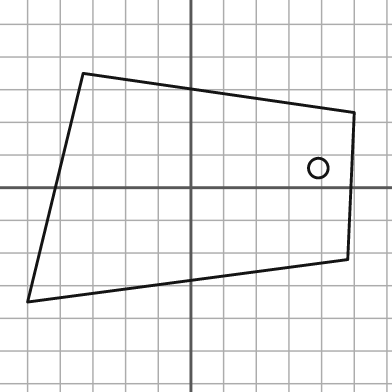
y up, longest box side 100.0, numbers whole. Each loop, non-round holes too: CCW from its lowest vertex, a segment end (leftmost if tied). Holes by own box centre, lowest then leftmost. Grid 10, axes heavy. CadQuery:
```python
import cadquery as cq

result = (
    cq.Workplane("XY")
    .moveTo(-50.0, -35.0)
    .lineTo(48.0, -22.0)
    .lineTo(50.0, 23.0)
    .lineTo(-33.0, 35.0)
    .close()
    .moveTo(39.0, 6.0)
    .circle(3.0)
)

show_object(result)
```